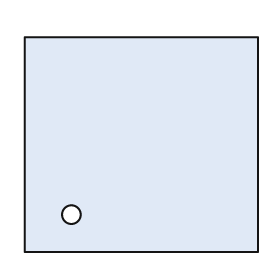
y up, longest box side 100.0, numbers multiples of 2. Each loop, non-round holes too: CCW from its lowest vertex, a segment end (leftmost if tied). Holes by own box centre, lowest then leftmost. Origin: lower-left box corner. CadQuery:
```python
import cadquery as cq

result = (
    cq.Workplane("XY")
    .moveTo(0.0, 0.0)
    .lineTo(100.0, 0.0)
    .lineTo(100.0, 92.0)
    .lineTo(0.0, 92.0)
    .close()
    .moveTo(20.0, 16.0)
    .circle(4.0)
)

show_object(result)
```